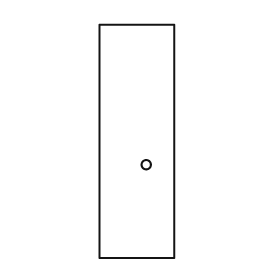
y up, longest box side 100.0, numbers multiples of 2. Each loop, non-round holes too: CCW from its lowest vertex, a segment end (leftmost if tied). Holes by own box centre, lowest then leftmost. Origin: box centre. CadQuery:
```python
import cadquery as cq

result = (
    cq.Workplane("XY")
    .moveTo(-16.0, -50.0)
    .lineTo(16.0, -50.0)
    .lineTo(16.0, 50.0)
    .lineTo(-16.0, 50.0)
    .close()
    .moveTo(4.0, -10.0)
    .circle(2.0)
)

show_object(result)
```